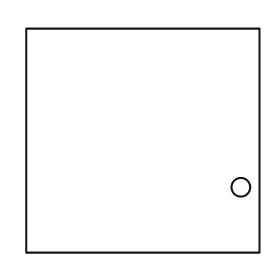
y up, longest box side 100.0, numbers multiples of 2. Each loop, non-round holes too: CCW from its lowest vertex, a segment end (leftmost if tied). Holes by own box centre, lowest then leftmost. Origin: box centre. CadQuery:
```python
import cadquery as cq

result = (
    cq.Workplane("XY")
    .moveTo(-50.0, -48.0)
    .lineTo(50.0, -48.0)
    .lineTo(50.0, 48.0)
    .lineTo(-50.0, 48.0)
    .close()
    .moveTo(42.0, -20.0)
    .circle(4.0)
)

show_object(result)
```